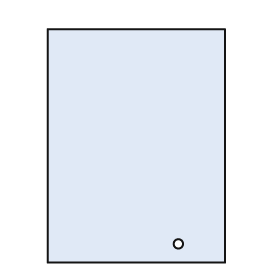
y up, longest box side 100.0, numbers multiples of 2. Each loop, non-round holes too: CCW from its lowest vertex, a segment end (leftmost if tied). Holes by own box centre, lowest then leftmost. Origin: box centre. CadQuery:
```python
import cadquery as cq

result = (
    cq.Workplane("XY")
    .moveTo(-38.0, -50.0)
    .lineTo(38.0, -50.0)
    .lineTo(38.0, 50.0)
    .lineTo(-38.0, 50.0)
    .close()
    .moveTo(18.0, -42.0)
    .circle(2.0)
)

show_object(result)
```